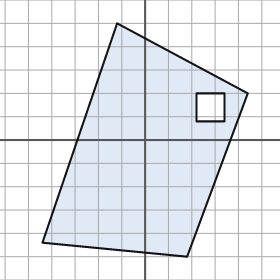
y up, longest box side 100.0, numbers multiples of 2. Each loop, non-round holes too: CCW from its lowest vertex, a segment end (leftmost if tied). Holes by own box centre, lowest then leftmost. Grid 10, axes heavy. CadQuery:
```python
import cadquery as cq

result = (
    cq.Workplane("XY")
    .moveTo(18.0, -50.0)
    .lineTo(44.0, 20.0)
    .lineTo(-12.0, 50.0)
    .lineTo(-44.0, -44.0)
    .close()
    .moveTo(22.0, 8.0)
    .lineTo(34.0, 8.0)
    .lineTo(34.0, 20.0)
    .lineTo(22.0, 20.0)
    .close()
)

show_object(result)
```